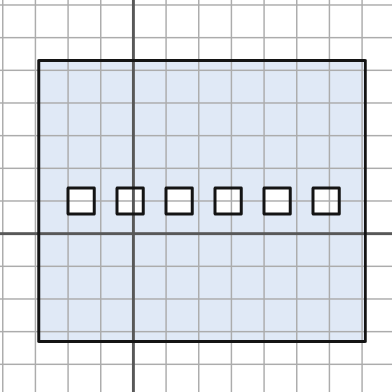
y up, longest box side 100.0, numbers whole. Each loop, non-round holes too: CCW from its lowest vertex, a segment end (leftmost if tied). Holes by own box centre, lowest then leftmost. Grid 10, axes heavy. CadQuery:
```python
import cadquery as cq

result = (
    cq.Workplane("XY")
    .moveTo(-29.0, -33.0)
    .lineTo(71.0, -33.0)
    .lineTo(71.0, 53.0)
    .lineTo(-29.0, 53.0)
    .close()
    .moveTo(-20.0, 6.0)
    .lineTo(-12.0, 6.0)
    .lineTo(-12.0, 14.0)
    .lineTo(-20.0, 14.0)
    .close()
    .moveTo(-5.0, 6.0)
    .lineTo(3.0, 6.0)
    .lineTo(3.0, 14.0)
    .lineTo(-5.0, 14.0)
    .close()
    .moveTo(10.0, 6.0)
    .lineTo(18.0, 6.0)
    .lineTo(18.0, 14.0)
    .lineTo(10.0, 14.0)
    .close()
    .moveTo(25.0, 6.0)
    .lineTo(33.0, 6.0)
    .lineTo(33.0, 14.0)
    .lineTo(25.0, 14.0)
    .close()
    .moveTo(40.0, 6.0)
    .lineTo(48.0, 6.0)
    .lineTo(48.0, 14.0)
    .lineTo(40.0, 14.0)
    .close()
    .moveTo(55.0, 6.0)
    .lineTo(63.0, 6.0)
    .lineTo(63.0, 14.0)
    .lineTo(55.0, 14.0)
    .close()
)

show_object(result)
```